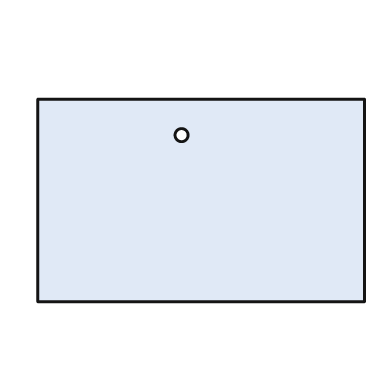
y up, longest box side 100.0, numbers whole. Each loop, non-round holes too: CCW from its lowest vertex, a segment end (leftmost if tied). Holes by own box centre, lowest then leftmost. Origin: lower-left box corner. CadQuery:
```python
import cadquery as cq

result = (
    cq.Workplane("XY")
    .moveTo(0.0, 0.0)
    .lineTo(100.0, 0.0)
    .lineTo(100.0, 62.0)
    .lineTo(0.0, 62.0)
    .close()
    .moveTo(44.0, 51.0)
    .circle(2.0)
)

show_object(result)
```